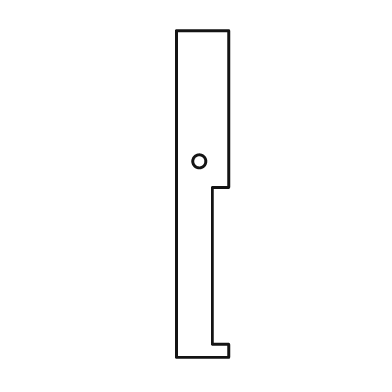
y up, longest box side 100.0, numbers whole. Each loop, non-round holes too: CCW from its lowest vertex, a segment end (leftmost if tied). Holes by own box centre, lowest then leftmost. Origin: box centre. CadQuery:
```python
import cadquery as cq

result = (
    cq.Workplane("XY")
    .moveTo(-8.0, -50.0)
    .lineTo(8.0, -50.0)
    .lineTo(8.0, -46.0)
    .lineTo(3.0, -46.0)
    .lineTo(3.0, 2.0)
    .lineTo(8.0, 2.0)
    .lineTo(8.0, 50.0)
    .lineTo(-8.0, 50.0)
    .close()
    .moveTo(-1.0, 10.0)
    .circle(2.0)
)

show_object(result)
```